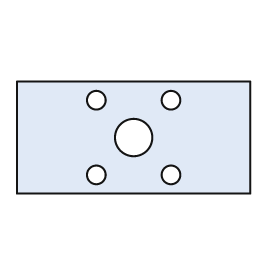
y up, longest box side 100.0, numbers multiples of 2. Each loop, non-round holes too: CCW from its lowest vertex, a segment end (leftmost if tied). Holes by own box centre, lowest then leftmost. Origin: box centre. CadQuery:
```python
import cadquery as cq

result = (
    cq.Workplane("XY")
    .moveTo(-50.0, -24.0)
    .lineTo(50.0, -24.0)
    .lineTo(50.0, 24.0)
    .lineTo(-50.0, 24.0)
    .close()
    .moveTo(-16.0, -16.0)
    .circle(4.0)
    .moveTo(16.0, -16.0)
    .circle(4.0)
    .moveTo(0.0, 0.0)
    .circle(8.0)
    .moveTo(-16.0, 16.0)
    .circle(4.0)
    .moveTo(16.0, 16.0)
    .circle(4.0)
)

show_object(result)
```